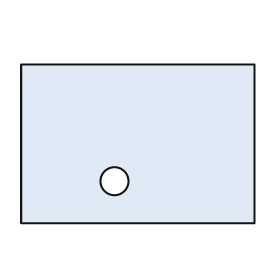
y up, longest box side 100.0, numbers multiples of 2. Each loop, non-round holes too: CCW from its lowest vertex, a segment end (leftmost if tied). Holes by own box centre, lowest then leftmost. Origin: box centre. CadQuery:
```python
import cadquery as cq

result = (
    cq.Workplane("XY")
    .moveTo(-50.0, -34.0)
    .lineTo(50.0, -34.0)
    .lineTo(50.0, 34.0)
    .lineTo(-50.0, 34.0)
    .close()
    .moveTo(-10.0, -16.0)
    .circle(6.0)
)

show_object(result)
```